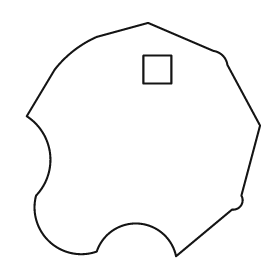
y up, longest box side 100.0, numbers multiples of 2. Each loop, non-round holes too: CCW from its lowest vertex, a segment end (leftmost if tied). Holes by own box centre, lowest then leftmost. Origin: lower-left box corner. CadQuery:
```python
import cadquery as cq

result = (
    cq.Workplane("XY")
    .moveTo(64.0, 0.0)
    .lineTo(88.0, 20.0)
    .threePointArc((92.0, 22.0), (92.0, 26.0))
    .lineTo(100.0, 56.0)
    .lineTo(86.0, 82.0)
    .threePointArc((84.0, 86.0), (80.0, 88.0))
    .lineTo(52.0, 100.0)
    .lineTo(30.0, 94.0)
    .threePointArc((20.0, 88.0), (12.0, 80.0))
    .lineTo(0.0, 60.0)
    .threePointArc((10.0, 44.0), (4.0, 26.0))
    .threePointArc((10.0, 6.0), (30.0, 2.0))
    .threePointArc((48.0, 14.0), (64.0, 0.0))
    .close()
    .moveTo(50.0, 74.0)
    .lineTo(62.0, 74.0)
    .lineTo(62.0, 86.0)
    .lineTo(50.0, 86.0)
    .close()
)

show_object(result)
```